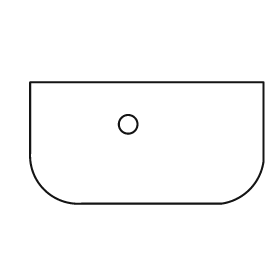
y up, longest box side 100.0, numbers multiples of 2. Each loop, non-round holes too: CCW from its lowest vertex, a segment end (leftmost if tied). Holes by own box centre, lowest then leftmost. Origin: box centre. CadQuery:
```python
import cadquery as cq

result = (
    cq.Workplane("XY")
    .moveTo(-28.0, -26.0)
    .lineTo(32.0, -26.0)
    .threePointArc((44.0, -20.0), (50.0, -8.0))
    .lineTo(50.0, 26.0)
    .lineTo(-50.0, 26.0)
    .lineTo(-50.0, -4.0)
    .threePointArc((-44.0, -20.0), (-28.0, -26.0))
    .close()
    .moveTo(-8.0, 8.0)
    .circle(4.0)
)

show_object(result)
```